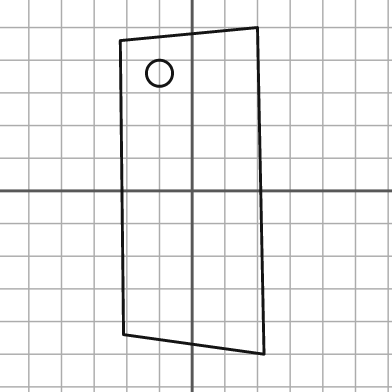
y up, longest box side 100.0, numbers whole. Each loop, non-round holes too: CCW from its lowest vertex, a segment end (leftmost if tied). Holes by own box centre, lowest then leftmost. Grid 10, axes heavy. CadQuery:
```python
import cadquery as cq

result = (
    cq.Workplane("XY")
    .moveTo(22.0, -50.0)
    .lineTo(20.0, 50.0)
    .lineTo(-22.0, 46.0)
    .lineTo(-21.0, -44.0)
    .close()
    .moveTo(-10.0, 36.0)
    .circle(4.0)
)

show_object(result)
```